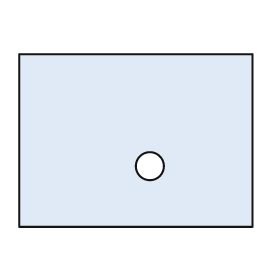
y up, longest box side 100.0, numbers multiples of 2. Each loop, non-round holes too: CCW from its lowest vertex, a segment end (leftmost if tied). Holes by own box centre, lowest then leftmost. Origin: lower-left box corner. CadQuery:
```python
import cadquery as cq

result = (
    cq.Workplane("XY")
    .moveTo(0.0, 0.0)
    .lineTo(100.0, 0.0)
    .lineTo(100.0, 74.0)
    .lineTo(0.0, 74.0)
    .close()
    .moveTo(56.0, 26.0)
    .circle(6.0)
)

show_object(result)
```